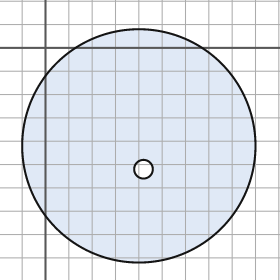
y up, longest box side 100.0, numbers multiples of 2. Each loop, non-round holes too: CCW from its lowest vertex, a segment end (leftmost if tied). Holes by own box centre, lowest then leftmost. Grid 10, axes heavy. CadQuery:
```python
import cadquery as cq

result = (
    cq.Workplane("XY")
    .moveTo(40.0, -42.0)
    .circle(50.0)
    .moveTo(42.0, -52.0)
    .circle(4.0)
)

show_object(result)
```